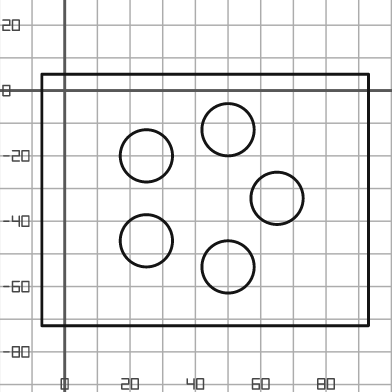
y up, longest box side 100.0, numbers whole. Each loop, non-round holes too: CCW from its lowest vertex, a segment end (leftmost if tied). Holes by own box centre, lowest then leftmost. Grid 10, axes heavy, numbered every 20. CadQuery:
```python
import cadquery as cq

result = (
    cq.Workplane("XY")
    .moveTo(-7.0, -72.0)
    .lineTo(93.0, -72.0)
    .lineTo(93.0, 5.0)
    .lineTo(-7.0, 5.0)
    .close()
    .moveTo(50.0, -54.0)
    .circle(8.0)
    .moveTo(25.0, -46.0)
    .circle(8.0)
    .moveTo(65.0, -33.0)
    .circle(8.0)
    .moveTo(25.0, -20.0)
    .circle(8.0)
    .moveTo(50.0, -12.0)
    .circle(8.0)
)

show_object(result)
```